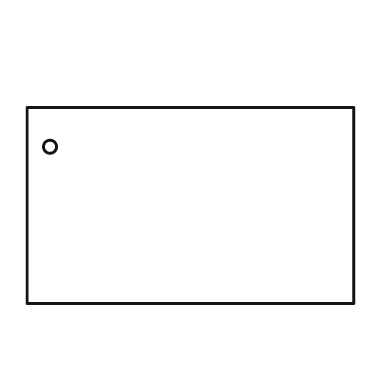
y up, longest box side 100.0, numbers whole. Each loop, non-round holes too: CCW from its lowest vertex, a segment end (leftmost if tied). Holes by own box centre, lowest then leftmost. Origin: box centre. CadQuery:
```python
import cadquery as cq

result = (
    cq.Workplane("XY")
    .moveTo(-50.0, -30.0)
    .lineTo(50.0, -30.0)
    .lineTo(50.0, 30.0)
    .lineTo(-50.0, 30.0)
    .close()
    .moveTo(-43.0, 18.0)
    .circle(2.0)
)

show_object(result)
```